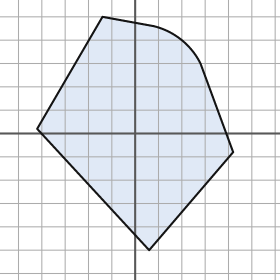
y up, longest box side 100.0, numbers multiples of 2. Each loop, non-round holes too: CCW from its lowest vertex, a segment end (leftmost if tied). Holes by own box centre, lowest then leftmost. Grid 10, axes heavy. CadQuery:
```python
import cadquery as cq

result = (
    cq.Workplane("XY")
    .moveTo(6.0, -50.0)
    .lineTo(42.0, -8.0)
    .lineTo(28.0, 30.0)
    .threePointArc((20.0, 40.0), (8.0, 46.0))
    .lineTo(-14.0, 50.0)
    .lineTo(-42.0, 2.0)
    .close()
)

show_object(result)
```